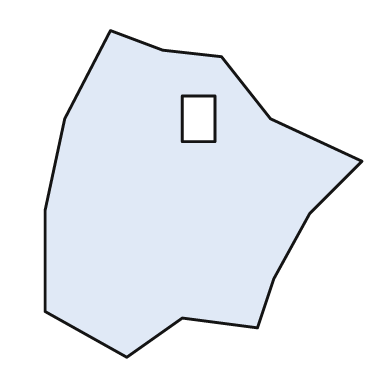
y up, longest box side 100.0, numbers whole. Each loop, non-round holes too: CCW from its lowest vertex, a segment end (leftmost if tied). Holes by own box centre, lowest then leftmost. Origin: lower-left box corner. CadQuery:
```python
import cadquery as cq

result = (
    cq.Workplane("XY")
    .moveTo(25.0, 0.0)
    .lineTo(42.0, 12.0)
    .lineTo(65.0, 9.0)
    .lineTo(70.0, 24.0)
    .lineTo(81.0, 44.0)
    .lineTo(97.0, 60.0)
    .lineTo(69.0, 73.0)
    .lineTo(54.0, 92.0)
    .lineTo(36.0, 94.0)
    .lineTo(20.0, 100.0)
    .lineTo(6.0, 73.0)
    .lineTo(0.0, 45.0)
    .lineTo(0.0, 14.0)
    .close()
    .moveTo(42.0, 66.0)
    .lineTo(52.0, 66.0)
    .lineTo(52.0, 80.0)
    .lineTo(42.0, 80.0)
    .close()
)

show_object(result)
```